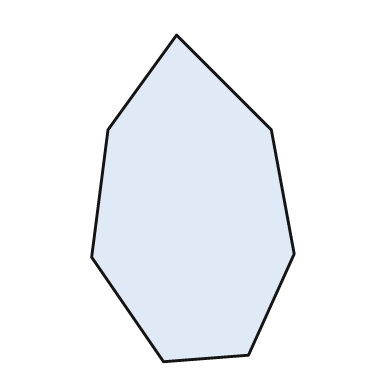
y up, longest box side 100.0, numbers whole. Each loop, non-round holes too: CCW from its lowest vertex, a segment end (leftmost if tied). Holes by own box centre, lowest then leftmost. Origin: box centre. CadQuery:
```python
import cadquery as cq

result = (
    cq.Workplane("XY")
    .moveTo(-9.0, -50.0)
    .lineTo(17.0, -48.0)
    .lineTo(31.0, -17.0)
    .lineTo(24.0, 21.0)
    .lineTo(-5.0, 50.0)
    .lineTo(-26.0, 21.0)
    .lineTo(-31.0, -18.0)
    .close()
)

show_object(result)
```